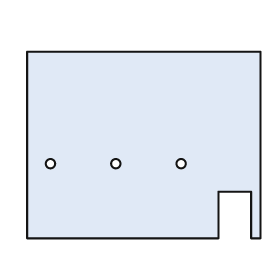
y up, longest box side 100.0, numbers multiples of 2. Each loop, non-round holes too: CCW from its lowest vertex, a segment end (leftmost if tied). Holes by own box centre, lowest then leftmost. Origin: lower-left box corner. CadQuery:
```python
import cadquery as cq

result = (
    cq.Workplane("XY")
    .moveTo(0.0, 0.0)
    .lineTo(82.0, 0.0)
    .lineTo(82.0, 20.0)
    .lineTo(96.0, 20.0)
    .lineTo(96.0, 0.0)
    .lineTo(100.0, 0.0)
    .lineTo(100.0, 80.0)
    .lineTo(0.0, 80.0)
    .close()
    .moveTo(10.0, 32.0)
    .circle(2.0)
    .moveTo(38.0, 32.0)
    .circle(2.0)
    .moveTo(66.0, 32.0)
    .circle(2.0)
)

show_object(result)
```